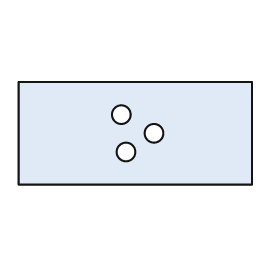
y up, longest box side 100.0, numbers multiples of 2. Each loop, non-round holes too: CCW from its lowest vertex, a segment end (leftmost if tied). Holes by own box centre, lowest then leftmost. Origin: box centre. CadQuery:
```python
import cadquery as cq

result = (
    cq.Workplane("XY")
    .moveTo(-50.0, -22.0)
    .lineTo(50.0, -22.0)
    .lineTo(50.0, 22.0)
    .lineTo(-50.0, 22.0)
    .close()
    .moveTo(-4.0, -8.0)
    .circle(4.0)
    .moveTo(8.0, 0.0)
    .circle(4.0)
    .moveTo(-6.0, 8.0)
    .circle(4.0)
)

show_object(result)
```